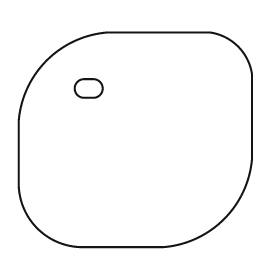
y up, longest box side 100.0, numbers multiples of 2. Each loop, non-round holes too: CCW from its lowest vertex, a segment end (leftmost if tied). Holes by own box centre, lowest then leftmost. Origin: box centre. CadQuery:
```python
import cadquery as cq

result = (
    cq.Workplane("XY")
    .moveTo(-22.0, -46.0)
    .lineTo(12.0, -46.0)
    .threePointArc((38.0, -34.0), (50.0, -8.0))
    .lineTo(50.0, 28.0)
    .threePointArc((44.0, 40.0), (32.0, 46.0))
    .lineTo(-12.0, 46.0)
    .threePointArc((-38.0, 34.0), (-50.0, 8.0))
    .lineTo(-50.0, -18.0)
    .threePointArc((-42.0, -38.0), (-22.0, -46.0))
    .close()
    .moveTo(-22.0, 18.0)
    .lineTo(-18.0, 18.0)
    .threePointArc((-14.0, 22.0), (-18.0, 26.0))
    .lineTo(-22.0, 26.0)
    .threePointArc((-26.0, 22.0), (-22.0, 18.0))
    .close()
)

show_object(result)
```